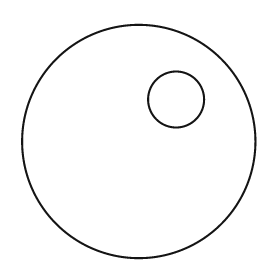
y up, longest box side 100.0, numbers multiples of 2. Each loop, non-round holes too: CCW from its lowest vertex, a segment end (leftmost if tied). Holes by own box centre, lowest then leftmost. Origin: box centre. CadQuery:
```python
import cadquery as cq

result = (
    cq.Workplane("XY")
    .moveTo(0.0, 0.0)
    .circle(50.0)
    .moveTo(16.0, 18.0)
    .circle(12.0)
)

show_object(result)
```